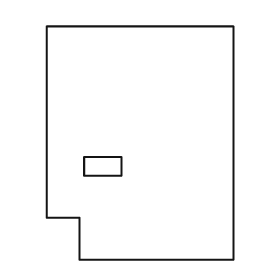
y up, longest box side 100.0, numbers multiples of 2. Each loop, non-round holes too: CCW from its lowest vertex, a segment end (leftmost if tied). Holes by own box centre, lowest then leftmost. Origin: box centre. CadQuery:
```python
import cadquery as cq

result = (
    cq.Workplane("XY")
    .moveTo(-26.0, -50.0)
    .lineTo(40.0, -50.0)
    .lineTo(40.0, 50.0)
    .lineTo(-40.0, 50.0)
    .lineTo(-40.0, -32.0)
    .lineTo(-26.0, -32.0)
    .close()
    .moveTo(-24.0, -14.0)
    .lineTo(-8.0, -14.0)
    .lineTo(-8.0, -6.0)
    .lineTo(-24.0, -6.0)
    .close()
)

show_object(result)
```